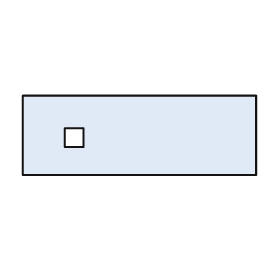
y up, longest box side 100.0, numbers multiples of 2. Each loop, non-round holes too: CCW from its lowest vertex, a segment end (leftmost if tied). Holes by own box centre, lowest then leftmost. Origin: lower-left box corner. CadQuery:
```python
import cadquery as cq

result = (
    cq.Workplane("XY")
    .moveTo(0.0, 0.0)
    .lineTo(100.0, 0.0)
    .lineTo(100.0, 34.0)
    .lineTo(0.0, 34.0)
    .close()
    .moveTo(18.0, 12.0)
    .lineTo(26.0, 12.0)
    .lineTo(26.0, 20.0)
    .lineTo(18.0, 20.0)
    .close()
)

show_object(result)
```